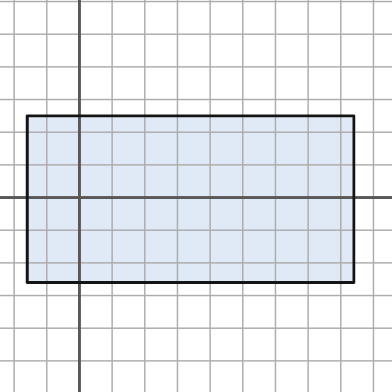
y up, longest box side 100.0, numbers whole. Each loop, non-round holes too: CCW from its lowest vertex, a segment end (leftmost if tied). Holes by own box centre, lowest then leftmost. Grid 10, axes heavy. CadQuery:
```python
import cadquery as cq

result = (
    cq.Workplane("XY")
    .moveTo(-16.0, -26.0)
    .lineTo(84.0, -26.0)
    .lineTo(84.0, 25.0)
    .lineTo(-16.0, 25.0)
    .close()
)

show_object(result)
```